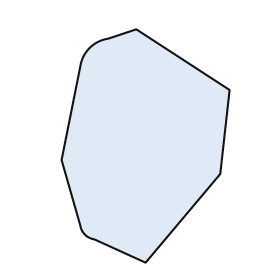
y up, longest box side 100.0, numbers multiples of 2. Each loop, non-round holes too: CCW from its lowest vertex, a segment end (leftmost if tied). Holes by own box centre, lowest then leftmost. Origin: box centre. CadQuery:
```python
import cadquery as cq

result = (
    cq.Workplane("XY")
    .moveTo(0.0, -50.0)
    .lineTo(32.0, -12.0)
    .lineTo(36.0, 24.0)
    .lineTo(-4.0, 50.0)
    .lineTo(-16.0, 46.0)
    .threePointArc((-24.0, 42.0), (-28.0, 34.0))
    .lineTo(-36.0, -6.0)
    .lineTo(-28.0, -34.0)
    .threePointArc((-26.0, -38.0), (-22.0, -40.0))
    .close()
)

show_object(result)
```